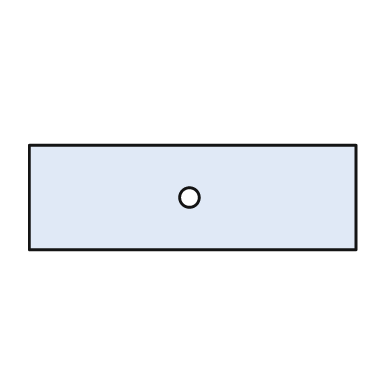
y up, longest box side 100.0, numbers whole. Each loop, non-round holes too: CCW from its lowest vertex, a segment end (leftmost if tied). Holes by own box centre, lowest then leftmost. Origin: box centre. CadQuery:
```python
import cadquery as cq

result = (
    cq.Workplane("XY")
    .moveTo(-50.0, -16.0)
    .lineTo(50.0, -16.0)
    .lineTo(50.0, 16.0)
    .lineTo(-50.0, 16.0)
    .close()
    .moveTo(-1.0, 0.0)
    .circle(3.0)
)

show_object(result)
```